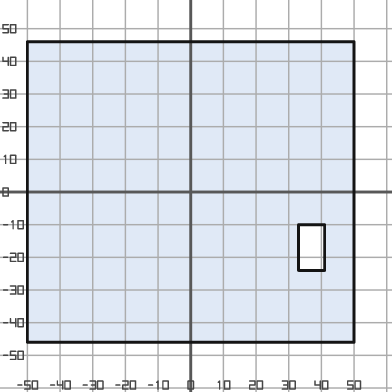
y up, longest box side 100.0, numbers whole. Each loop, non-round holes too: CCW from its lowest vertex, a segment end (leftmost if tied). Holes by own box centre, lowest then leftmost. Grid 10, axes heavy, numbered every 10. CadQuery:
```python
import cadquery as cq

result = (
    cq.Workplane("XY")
    .moveTo(-50.0, -46.0)
    .lineTo(50.0, -46.0)
    .lineTo(50.0, 46.0)
    .lineTo(-50.0, 46.0)
    .close()
    .moveTo(33.0, -24.0)
    .lineTo(41.0, -24.0)
    .lineTo(41.0, -10.0)
    .lineTo(33.0, -10.0)
    .close()
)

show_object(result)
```